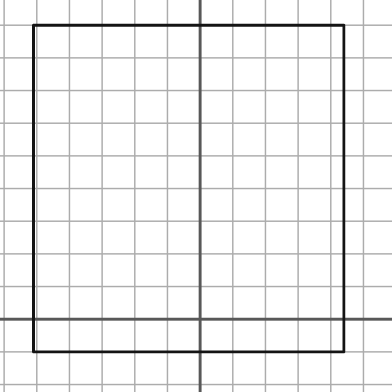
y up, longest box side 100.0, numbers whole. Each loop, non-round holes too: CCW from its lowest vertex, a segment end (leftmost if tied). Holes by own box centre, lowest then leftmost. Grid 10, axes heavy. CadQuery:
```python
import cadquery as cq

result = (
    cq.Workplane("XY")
    .moveTo(-51.0, -10.0)
    .lineTo(44.0, -10.0)
    .lineTo(44.0, 90.0)
    .lineTo(-51.0, 90.0)
    .close()
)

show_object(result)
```